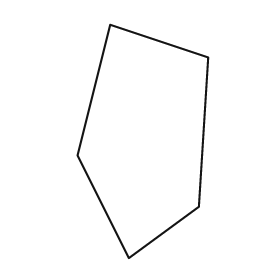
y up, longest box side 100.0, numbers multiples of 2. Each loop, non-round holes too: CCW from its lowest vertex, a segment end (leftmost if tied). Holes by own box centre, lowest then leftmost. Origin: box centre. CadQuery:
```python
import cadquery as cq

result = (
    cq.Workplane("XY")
    .moveTo(-6.0, -50.0)
    .lineTo(24.0, -28.0)
    .lineTo(28.0, 36.0)
    .lineTo(-14.0, 50.0)
    .lineTo(-28.0, -6.0)
    .close()
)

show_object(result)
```